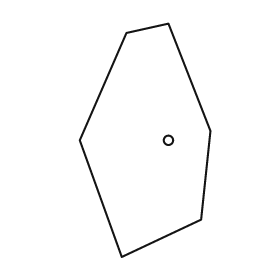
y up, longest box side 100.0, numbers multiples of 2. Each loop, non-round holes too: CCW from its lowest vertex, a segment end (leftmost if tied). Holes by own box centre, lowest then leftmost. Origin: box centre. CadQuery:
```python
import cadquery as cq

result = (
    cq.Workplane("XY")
    .moveTo(-10.0, -50.0)
    .lineTo(24.0, -34.0)
    .lineTo(28.0, 4.0)
    .lineTo(10.0, 50.0)
    .lineTo(-8.0, 46.0)
    .lineTo(-28.0, 0.0)
    .close()
    .moveTo(10.0, 0.0)
    .circle(2.0)
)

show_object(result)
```